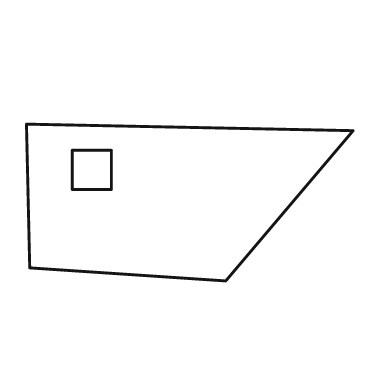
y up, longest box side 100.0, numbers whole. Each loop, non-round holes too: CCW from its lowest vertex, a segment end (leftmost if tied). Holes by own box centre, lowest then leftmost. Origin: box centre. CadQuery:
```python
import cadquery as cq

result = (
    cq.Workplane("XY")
    .moveTo(11.0, -24.0)
    .lineTo(50.0, 22.0)
    .lineTo(-50.0, 24.0)
    .lineTo(-49.0, -20.0)
    .close()
    .moveTo(-36.0, 4.0)
    .lineTo(-24.0, 4.0)
    .lineTo(-24.0, 16.0)
    .lineTo(-36.0, 16.0)
    .close()
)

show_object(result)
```